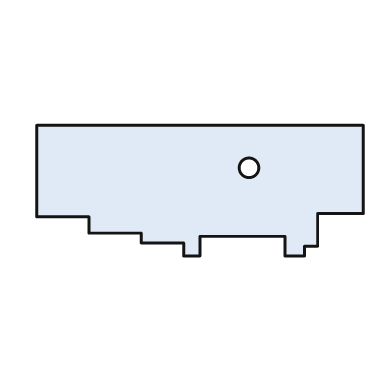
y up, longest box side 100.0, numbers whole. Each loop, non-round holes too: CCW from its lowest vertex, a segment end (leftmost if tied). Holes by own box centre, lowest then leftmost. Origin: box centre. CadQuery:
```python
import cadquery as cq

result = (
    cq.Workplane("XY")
    .moveTo(-5.0, -20.0)
    .lineTo(0.0, -20.0)
    .lineTo(0.0, -14.0)
    .lineTo(26.0, -14.0)
    .lineTo(26.0, -20.0)
    .lineTo(32.0, -20.0)
    .lineTo(32.0, -17.0)
    .lineTo(36.0, -17.0)
    .lineTo(36.0, -7.0)
    .lineTo(50.0, -7.0)
    .lineTo(50.0, 20.0)
    .lineTo(-50.0, 20.0)
    .lineTo(-50.0, -8.0)
    .lineTo(-34.0, -8.0)
    .lineTo(-34.0, -13.0)
    .lineTo(-18.0, -13.0)
    .lineTo(-18.0, -16.0)
    .lineTo(-5.0, -16.0)
    .close()
    .moveTo(15.0, 7.0)
    .circle(3.0)
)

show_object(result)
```